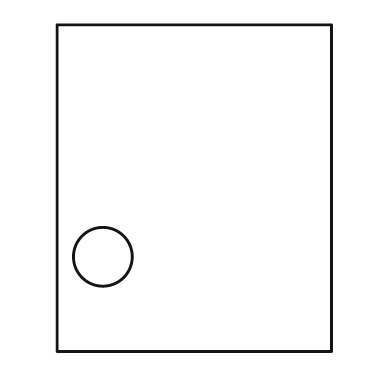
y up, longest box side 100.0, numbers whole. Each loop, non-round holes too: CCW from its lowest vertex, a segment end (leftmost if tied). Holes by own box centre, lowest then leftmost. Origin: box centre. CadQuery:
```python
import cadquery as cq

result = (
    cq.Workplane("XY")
    .moveTo(-42.0, -50.0)
    .lineTo(42.0, -50.0)
    .lineTo(42.0, 50.0)
    .lineTo(-42.0, 50.0)
    .close()
    .moveTo(-28.0, -21.0)
    .circle(9.0)
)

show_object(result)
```